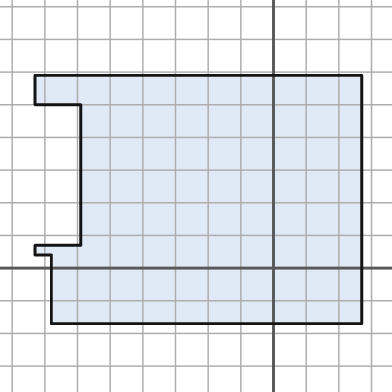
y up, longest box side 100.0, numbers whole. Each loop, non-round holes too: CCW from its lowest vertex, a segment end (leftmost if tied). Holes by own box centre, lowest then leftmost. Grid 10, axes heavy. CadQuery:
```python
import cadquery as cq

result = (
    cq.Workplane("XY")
    .moveTo(-68.0, -17.0)
    .lineTo(27.0, -17.0)
    .lineTo(27.0, 59.0)
    .lineTo(-73.0, 59.0)
    .lineTo(-73.0, 50.0)
    .lineTo(-59.0, 50.0)
    .lineTo(-59.0, 7.0)
    .lineTo(-73.0, 7.0)
    .lineTo(-73.0, 4.0)
    .lineTo(-68.0, 4.0)
    .close()
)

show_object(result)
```